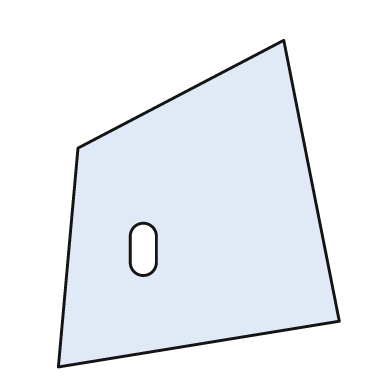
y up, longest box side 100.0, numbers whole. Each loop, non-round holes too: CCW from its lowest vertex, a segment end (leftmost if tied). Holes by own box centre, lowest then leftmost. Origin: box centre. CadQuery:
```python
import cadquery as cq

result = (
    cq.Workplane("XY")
    .moveTo(-43.0, -50.0)
    .lineTo(43.0, -36.0)
    .lineTo(26.0, 50.0)
    .lineTo(-37.0, 17.0)
    .close()
    .moveTo(-21.0, -18.0)
    .threePointArc((-17.0, -22.0), (-13.0, -18.0))
    .lineTo(-13.0, -10.0)
    .threePointArc((-17.0, -6.0), (-21.0, -10.0))
    .close()
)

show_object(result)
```